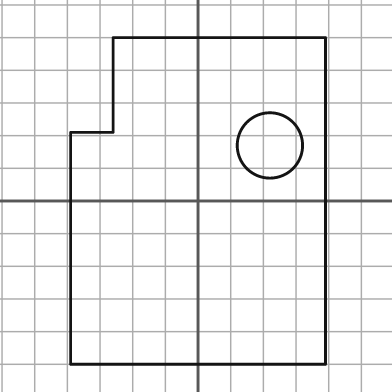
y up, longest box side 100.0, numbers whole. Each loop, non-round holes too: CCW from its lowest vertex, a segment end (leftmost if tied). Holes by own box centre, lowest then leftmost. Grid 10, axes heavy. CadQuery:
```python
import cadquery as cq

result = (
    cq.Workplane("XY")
    .moveTo(-39.0, -50.0)
    .lineTo(39.0, -50.0)
    .lineTo(39.0, 50.0)
    .lineTo(-26.0, 50.0)
    .lineTo(-26.0, 21.0)
    .lineTo(-39.0, 21.0)
    .close()
    .moveTo(22.0, 17.0)
    .circle(10.0)
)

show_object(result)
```